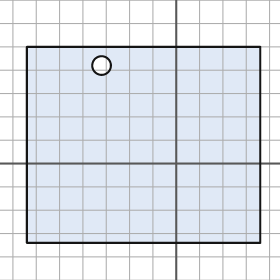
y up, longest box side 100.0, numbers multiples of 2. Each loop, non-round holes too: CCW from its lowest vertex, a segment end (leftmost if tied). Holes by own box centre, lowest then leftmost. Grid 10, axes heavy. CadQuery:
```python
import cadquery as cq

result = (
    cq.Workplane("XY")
    .moveTo(-64.0, -34.0)
    .lineTo(36.0, -34.0)
    .lineTo(36.0, 50.0)
    .lineTo(-64.0, 50.0)
    .close()
    .moveTo(-32.0, 42.0)
    .circle(4.0)
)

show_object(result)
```